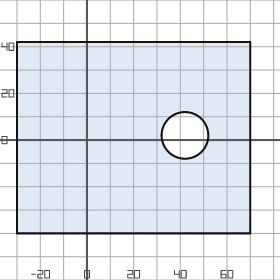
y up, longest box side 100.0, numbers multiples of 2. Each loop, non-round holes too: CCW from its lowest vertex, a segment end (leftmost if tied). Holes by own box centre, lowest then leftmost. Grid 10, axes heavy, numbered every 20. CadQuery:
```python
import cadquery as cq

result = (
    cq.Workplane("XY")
    .moveTo(-30.0, -40.0)
    .lineTo(70.0, -40.0)
    .lineTo(70.0, 42.0)
    .lineTo(-30.0, 42.0)
    .close()
    .moveTo(42.0, 2.0)
    .circle(10.0)
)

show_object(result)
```